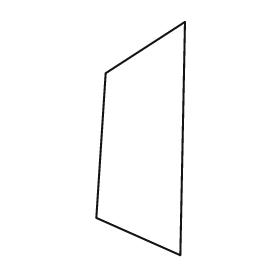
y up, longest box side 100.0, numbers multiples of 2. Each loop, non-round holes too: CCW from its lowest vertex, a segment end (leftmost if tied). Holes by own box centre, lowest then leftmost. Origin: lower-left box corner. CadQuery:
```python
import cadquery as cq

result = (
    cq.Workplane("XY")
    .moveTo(36.0, 0.0)
    .lineTo(38.0, 100.0)
    .lineTo(4.0, 78.0)
    .lineTo(0.0, 16.0)
    .close()
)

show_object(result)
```